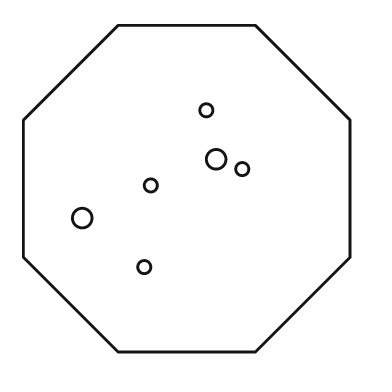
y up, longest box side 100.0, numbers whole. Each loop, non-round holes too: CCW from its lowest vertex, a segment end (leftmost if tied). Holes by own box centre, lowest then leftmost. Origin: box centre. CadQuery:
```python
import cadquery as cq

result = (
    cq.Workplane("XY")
    .moveTo(-21.0, -50.0)
    .lineTo(21.0, -50.0)
    .lineTo(50.0, -21.0)
    .lineTo(50.0, 21.0)
    .lineTo(21.0, 50.0)
    .lineTo(-21.0, 50.0)
    .lineTo(-50.0, 21.0)
    .lineTo(-50.0, -21.0)
    .close()
    .moveTo(-13.0, -24.0)
    .circle(2.0)
    .moveTo(-32.0, -9.0)
    .circle(3.0)
    .moveTo(-11.0, 1.0)
    .circle(2.0)
    .moveTo(17.0, 6.0)
    .circle(2.0)
    .moveTo(9.0, 9.0)
    .circle(3.0)
    .moveTo(6.0, 24.0)
    .circle(2.0)
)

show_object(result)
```